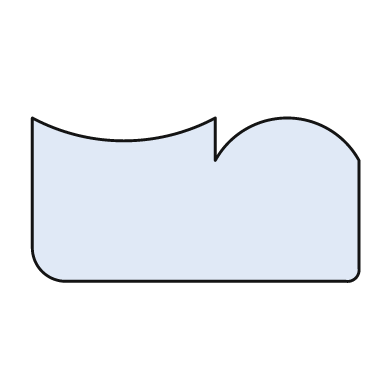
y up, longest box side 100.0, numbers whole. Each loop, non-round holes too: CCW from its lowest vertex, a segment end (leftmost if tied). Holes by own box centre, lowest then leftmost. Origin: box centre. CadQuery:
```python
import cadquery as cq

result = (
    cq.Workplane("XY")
    .moveTo(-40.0, -25.0)
    .lineTo(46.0, -25.0)
    .threePointArc((49.0, -24.0), (50.0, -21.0))
    .lineTo(50.0, 12.0)
    .threePointArc((28.0, 25.0), (6.0, 12.0))
    .lineTo(6.0, 25.0)
    .threePointArc((-22.0, 18.0), (-50.0, 25.0))
    .lineTo(-50.0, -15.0)
    .threePointArc((-47.0, -22.0), (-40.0, -25.0))
    .close()
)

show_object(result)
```